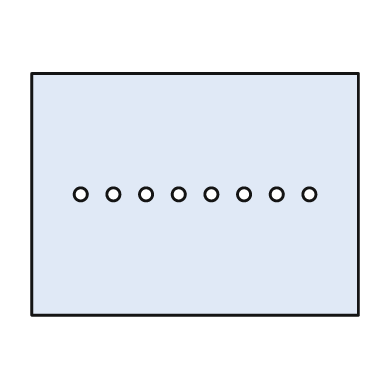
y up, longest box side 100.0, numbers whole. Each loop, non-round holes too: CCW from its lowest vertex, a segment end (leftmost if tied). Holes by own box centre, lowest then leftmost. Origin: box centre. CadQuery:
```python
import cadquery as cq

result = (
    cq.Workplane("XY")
    .moveTo(-50.0, -37.0)
    .lineTo(50.0, -37.0)
    .lineTo(50.0, 37.0)
    .lineTo(-50.0, 37.0)
    .close()
    .moveTo(-35.0, 0.0)
    .circle(2.0)
    .moveTo(-25.0, 0.0)
    .circle(2.0)
    .moveTo(-15.0, 0.0)
    .circle(2.0)
    .moveTo(-5.0, 0.0)
    .circle(2.0)
    .moveTo(5.0, 0.0)
    .circle(2.0)
    .moveTo(15.0, 0.0)
    .circle(2.0)
    .moveTo(25.0, 0.0)
    .circle(2.0)
    .moveTo(35.0, 0.0)
    .circle(2.0)
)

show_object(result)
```